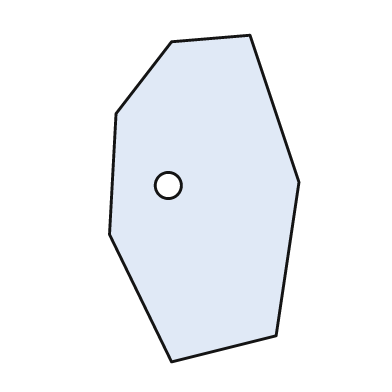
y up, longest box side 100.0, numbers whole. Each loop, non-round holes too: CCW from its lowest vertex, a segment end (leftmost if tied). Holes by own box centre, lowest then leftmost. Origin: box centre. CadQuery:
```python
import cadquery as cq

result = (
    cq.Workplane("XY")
    .moveTo(-10.0, -50.0)
    .lineTo(22.0, -42.0)
    .lineTo(29.0, 5.0)
    .lineTo(14.0, 50.0)
    .lineTo(-10.0, 48.0)
    .lineTo(-27.0, 26.0)
    .lineTo(-29.0, -11.0)
    .close()
    .moveTo(-11.0, 4.0)
    .circle(4.0)
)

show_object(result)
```